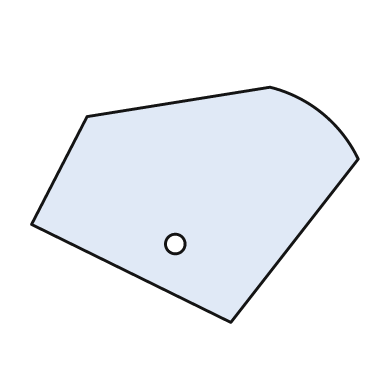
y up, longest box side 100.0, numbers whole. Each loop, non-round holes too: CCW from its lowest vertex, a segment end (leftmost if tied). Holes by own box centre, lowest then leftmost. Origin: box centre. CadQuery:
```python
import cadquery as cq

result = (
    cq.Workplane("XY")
    .moveTo(11.0, -36.0)
    .lineTo(50.0, 14.0)
    .threePointArc((39.0, 28.0), (23.0, 36.0))
    .lineTo(-33.0, 27.0)
    .lineTo(-50.0, -6.0)
    .close()
    .moveTo(-6.0, -12.0)
    .circle(3.0)
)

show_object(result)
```